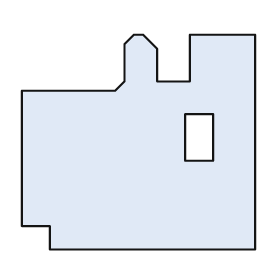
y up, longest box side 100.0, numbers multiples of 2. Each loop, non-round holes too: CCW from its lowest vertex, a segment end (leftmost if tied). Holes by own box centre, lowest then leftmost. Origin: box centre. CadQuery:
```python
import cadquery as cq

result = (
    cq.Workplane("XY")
    .moveTo(-38.0, -46.0)
    .lineTo(50.0, -46.0)
    .lineTo(50.0, 46.0)
    .lineTo(22.0, 46.0)
    .lineTo(22.0, 26.0)
    .lineTo(8.0, 26.0)
    .lineTo(8.0, 40.0)
    .lineTo(2.0, 46.0)
    .lineTo(-2.0, 46.0)
    .lineTo(-6.0, 42.0)
    .lineTo(-6.0, 26.0)
    .lineTo(-10.0, 22.0)
    .lineTo(-50.0, 22.0)
    .lineTo(-50.0, -36.0)
    .lineTo(-38.0, -36.0)
    .close()
    .moveTo(20.0, -8.0)
    .lineTo(32.0, -8.0)
    .lineTo(32.0, 12.0)
    .lineTo(20.0, 12.0)
    .close()
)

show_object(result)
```